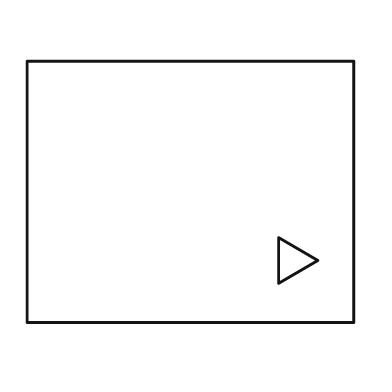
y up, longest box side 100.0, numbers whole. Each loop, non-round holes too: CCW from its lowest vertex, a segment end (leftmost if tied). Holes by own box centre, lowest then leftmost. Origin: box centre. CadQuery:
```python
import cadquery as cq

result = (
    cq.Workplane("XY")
    .moveTo(-50.0, -40.0)
    .lineTo(50.0, -40.0)
    .lineTo(50.0, 40.0)
    .lineTo(-50.0, 40.0)
    .close()
    .moveTo(27.0, -28.0)
    .lineTo(39.0, -21.0)
    .lineTo(27.0, -14.0)
    .close()
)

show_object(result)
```